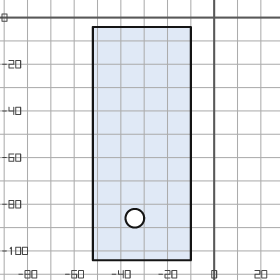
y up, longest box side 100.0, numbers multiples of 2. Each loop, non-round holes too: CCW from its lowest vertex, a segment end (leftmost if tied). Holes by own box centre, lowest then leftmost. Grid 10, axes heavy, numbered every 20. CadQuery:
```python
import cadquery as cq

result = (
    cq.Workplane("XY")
    .moveTo(-52.0, -104.0)
    .lineTo(-10.0, -104.0)
    .lineTo(-10.0, -4.0)
    .lineTo(-52.0, -4.0)
    .close()
    .moveTo(-34.0, -86.0)
    .circle(4.0)
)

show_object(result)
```